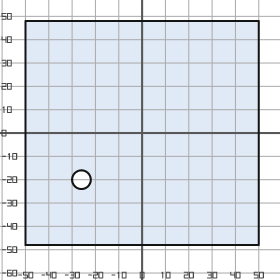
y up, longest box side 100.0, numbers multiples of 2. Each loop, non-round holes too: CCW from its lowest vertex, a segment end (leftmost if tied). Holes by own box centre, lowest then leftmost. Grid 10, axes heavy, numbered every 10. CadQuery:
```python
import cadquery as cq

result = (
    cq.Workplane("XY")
    .moveTo(-50.0, -48.0)
    .lineTo(50.0, -48.0)
    .lineTo(50.0, 48.0)
    .lineTo(-50.0, 48.0)
    .close()
    .moveTo(-26.0, -20.0)
    .circle(4.0)
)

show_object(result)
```